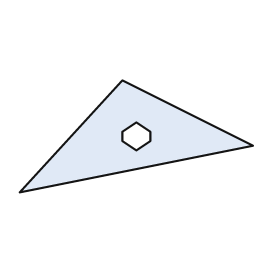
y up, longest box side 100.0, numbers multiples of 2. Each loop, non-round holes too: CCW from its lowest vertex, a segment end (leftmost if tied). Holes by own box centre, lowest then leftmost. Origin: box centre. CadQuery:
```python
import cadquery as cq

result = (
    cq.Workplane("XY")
    .moveTo(-50.0, -24.0)
    .lineTo(50.0, -4.0)
    .lineTo(-6.0, 24.0)
    .close()
    .moveTo(0.0, -6.0)
    .lineTo(6.0, -2.0)
    .lineTo(6.0, 2.0)
    .lineTo(0.0, 6.0)
    .lineTo(-6.0, 2.0)
    .lineTo(-6.0, -2.0)
    .close()
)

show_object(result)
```